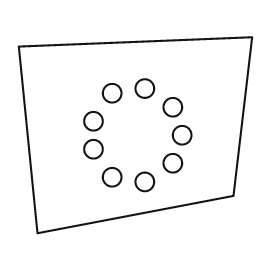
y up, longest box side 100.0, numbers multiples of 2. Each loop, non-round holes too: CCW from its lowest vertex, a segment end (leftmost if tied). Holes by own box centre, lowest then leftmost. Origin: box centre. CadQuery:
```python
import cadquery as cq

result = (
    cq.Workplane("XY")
    .moveTo(-42.0, -42.0)
    .lineTo(42.0, -26.0)
    .lineTo(50.0, 42.0)
    .lineTo(-50.0, 38.0)
    .close()
    .moveTo(4.0, -20.0)
    .circle(4.0)
    .moveTo(-10.0, -18.0)
    .circle(4.0)
    .moveTo(16.0, -12.0)
    .circle(4.0)
    .moveTo(-18.0, -6.0)
    .circle(4.0)
    .moveTo(20.0, 0.0)
    .circle(4.0)
    .moveTo(-18.0, 6.0)
    .circle(4.0)
    .moveTo(16.0, 12.0)
    .circle(4.0)
    .moveTo(-10.0, 18.0)
    .circle(4.0)
    .moveTo(4.0, 20.0)
    .circle(4.0)
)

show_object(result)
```